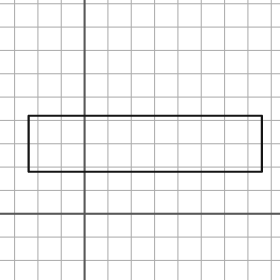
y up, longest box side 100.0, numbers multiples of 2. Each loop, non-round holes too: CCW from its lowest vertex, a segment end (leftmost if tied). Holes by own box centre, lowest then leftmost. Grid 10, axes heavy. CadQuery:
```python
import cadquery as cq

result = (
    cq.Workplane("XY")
    .moveTo(-24.0, 18.0)
    .lineTo(76.0, 18.0)
    .lineTo(76.0, 42.0)
    .lineTo(-24.0, 42.0)
    .close()
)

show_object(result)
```